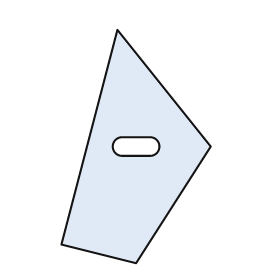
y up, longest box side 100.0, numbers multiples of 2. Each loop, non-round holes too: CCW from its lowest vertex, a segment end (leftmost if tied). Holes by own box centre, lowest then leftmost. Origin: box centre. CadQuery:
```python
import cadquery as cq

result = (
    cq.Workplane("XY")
    .moveTo(0.0, -50.0)
    .lineTo(32.0, 0.0)
    .lineTo(-8.0, 50.0)
    .lineTo(-32.0, -42.0)
    .close()
    .moveTo(-6.0, -4.0)
    .lineTo(6.0, -4.0)
    .threePointArc((10.0, 0.0), (6.0, 4.0))
    .lineTo(-6.0, 4.0)
    .threePointArc((-10.0, 0.0), (-6.0, -4.0))
    .close()
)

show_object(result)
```